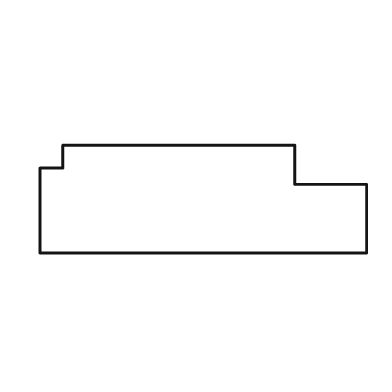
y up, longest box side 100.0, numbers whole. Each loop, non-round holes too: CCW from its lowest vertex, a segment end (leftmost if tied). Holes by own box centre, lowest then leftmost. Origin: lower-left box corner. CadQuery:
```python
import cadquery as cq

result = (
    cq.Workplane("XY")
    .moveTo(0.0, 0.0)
    .lineTo(100.0, 0.0)
    .lineTo(100.0, 21.0)
    .lineTo(78.0, 21.0)
    .lineTo(78.0, 33.0)
    .lineTo(7.0, 33.0)
    .lineTo(7.0, 26.0)
    .lineTo(0.0, 26.0)
    .close()
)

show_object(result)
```